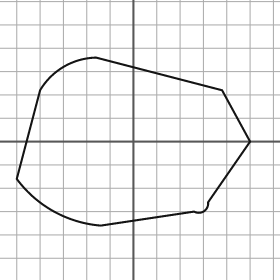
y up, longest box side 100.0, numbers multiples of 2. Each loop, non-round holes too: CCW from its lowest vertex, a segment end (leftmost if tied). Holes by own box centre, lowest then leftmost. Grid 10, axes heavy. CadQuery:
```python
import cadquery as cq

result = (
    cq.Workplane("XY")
    .moveTo(-14.0, -36.0)
    .lineTo(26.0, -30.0)
    .threePointArc((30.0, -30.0), (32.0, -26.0))
    .lineTo(50.0, 0.0)
    .lineTo(38.0, 22.0)
    .lineTo(-16.0, 36.0)
    .threePointArc((-30.0, 32.0), (-40.0, 22.0))
    .lineTo(-50.0, -16.0)
    .threePointArc((-34.0, -30.0), (-14.0, -36.0))
    .close()
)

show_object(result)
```